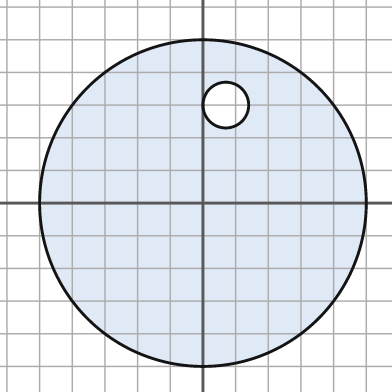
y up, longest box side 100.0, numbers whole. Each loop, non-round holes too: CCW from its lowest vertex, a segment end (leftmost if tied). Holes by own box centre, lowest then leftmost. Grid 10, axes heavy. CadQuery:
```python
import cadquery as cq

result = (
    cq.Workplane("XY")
    .moveTo(0.0, 0.0)
    .circle(50.0)
    .moveTo(7.0, 30.0)
    .circle(7.0)
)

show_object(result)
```